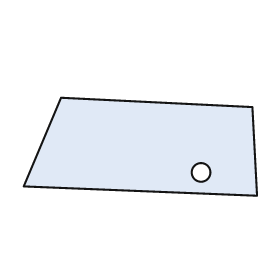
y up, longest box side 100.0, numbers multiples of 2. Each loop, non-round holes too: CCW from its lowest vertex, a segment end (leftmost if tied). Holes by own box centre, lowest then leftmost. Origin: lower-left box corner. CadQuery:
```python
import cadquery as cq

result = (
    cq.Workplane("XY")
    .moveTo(100.0, 0.0)
    .lineTo(98.0, 38.0)
    .lineTo(16.0, 42.0)
    .lineTo(0.0, 4.0)
    .close()
    .moveTo(76.0, 10.0)
    .circle(4.0)
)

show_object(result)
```